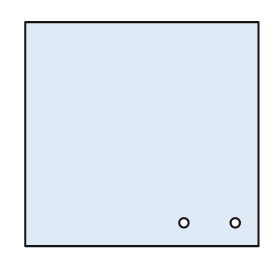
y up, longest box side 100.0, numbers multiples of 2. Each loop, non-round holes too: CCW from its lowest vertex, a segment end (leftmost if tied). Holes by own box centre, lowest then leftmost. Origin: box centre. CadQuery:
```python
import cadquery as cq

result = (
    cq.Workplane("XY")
    .moveTo(-50.0, -48.0)
    .lineTo(50.0, -48.0)
    .lineTo(50.0, 48.0)
    .lineTo(-50.0, 48.0)
    .close()
    .moveTo(18.0, -38.0)
    .circle(2.0)
    .moveTo(40.0, -38.0)
    .circle(2.0)
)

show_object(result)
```